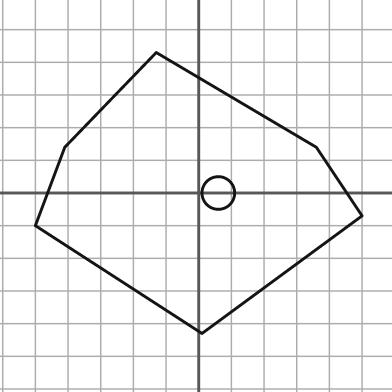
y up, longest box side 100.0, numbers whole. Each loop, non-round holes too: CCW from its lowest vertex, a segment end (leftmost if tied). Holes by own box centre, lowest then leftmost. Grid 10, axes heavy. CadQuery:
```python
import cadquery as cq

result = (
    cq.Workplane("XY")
    .moveTo(1.0, -43.0)
    .lineTo(50.0, -7.0)
    .lineTo(36.0, 14.0)
    .lineTo(-13.0, 43.0)
    .lineTo(-41.0, 14.0)
    .lineTo(-50.0, -10.0)
    .close()
    .moveTo(6.0, 0.0)
    .circle(5.0)
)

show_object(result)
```